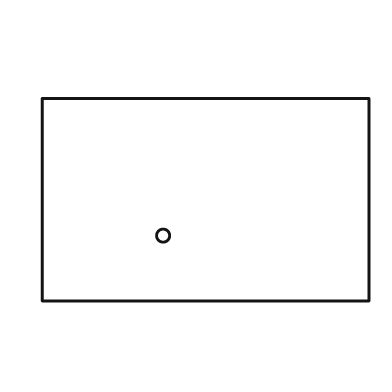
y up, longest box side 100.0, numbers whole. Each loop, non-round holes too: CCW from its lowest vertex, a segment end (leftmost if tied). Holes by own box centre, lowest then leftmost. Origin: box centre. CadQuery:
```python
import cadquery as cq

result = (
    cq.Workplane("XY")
    .moveTo(-50.0, -31.0)
    .lineTo(50.0, -31.0)
    .lineTo(50.0, 31.0)
    .lineTo(-50.0, 31.0)
    .close()
    .moveTo(-13.0, -11.0)
    .circle(2.0)
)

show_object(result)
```